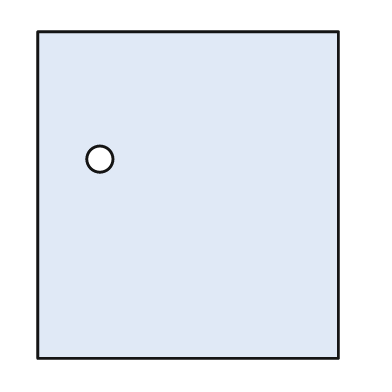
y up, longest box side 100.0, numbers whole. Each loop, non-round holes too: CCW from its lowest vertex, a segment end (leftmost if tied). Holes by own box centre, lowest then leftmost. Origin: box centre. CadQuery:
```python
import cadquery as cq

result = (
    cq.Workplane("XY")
    .moveTo(-46.0, -50.0)
    .lineTo(46.0, -50.0)
    .lineTo(46.0, 50.0)
    .lineTo(-46.0, 50.0)
    .close()
    .moveTo(-27.0, 11.0)
    .circle(4.0)
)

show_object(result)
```